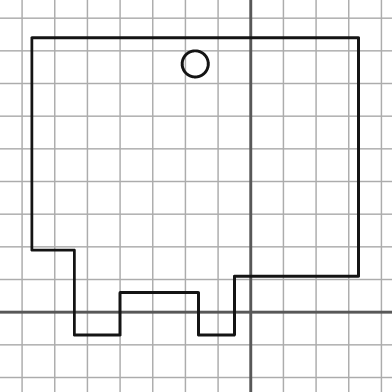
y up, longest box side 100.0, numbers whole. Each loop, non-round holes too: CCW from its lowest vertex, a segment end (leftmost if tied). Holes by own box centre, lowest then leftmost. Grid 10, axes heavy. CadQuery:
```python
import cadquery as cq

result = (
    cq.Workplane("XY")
    .moveTo(-54.0, -7.0)
    .lineTo(-40.0, -7.0)
    .lineTo(-40.0, 6.0)
    .lineTo(-16.0, 6.0)
    .lineTo(-16.0, -7.0)
    .lineTo(-5.0, -7.0)
    .lineTo(-5.0, 11.0)
    .lineTo(33.0, 11.0)
    .lineTo(33.0, 84.0)
    .lineTo(-67.0, 84.0)
    .lineTo(-67.0, 19.0)
    .lineTo(-54.0, 19.0)
    .close()
    .moveTo(-17.0, 76.0)
    .circle(4.0)
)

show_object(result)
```